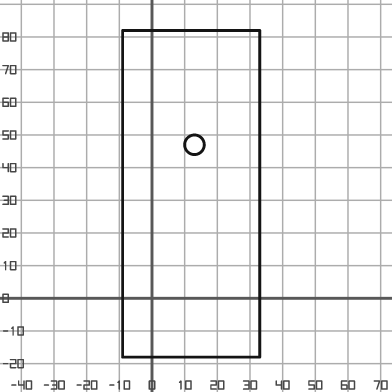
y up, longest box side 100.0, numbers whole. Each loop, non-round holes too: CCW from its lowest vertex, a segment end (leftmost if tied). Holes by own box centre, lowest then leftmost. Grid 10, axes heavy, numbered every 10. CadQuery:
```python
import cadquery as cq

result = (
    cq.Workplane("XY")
    .moveTo(-9.0, -18.0)
    .lineTo(33.0, -18.0)
    .lineTo(33.0, 82.0)
    .lineTo(-9.0, 82.0)
    .close()
    .moveTo(13.0, 47.0)
    .circle(3.0)
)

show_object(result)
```